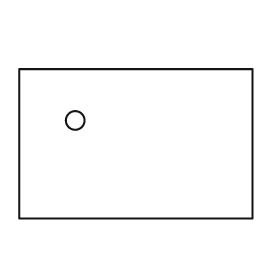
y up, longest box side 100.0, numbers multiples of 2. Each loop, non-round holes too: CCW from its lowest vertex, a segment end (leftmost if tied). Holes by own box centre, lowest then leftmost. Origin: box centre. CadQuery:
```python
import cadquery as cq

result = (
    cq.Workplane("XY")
    .moveTo(-50.0, -32.0)
    .lineTo(50.0, -32.0)
    .lineTo(50.0, 32.0)
    .lineTo(-50.0, 32.0)
    .close()
    .moveTo(-26.0, 10.0)
    .circle(4.0)
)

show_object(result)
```